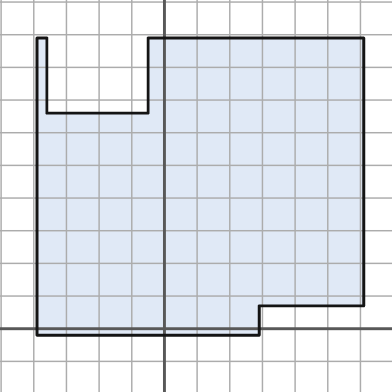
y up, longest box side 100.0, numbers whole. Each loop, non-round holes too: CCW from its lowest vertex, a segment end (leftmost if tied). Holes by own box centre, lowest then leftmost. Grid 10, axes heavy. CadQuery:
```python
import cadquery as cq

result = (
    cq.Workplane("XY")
    .moveTo(-39.0, -2.0)
    .lineTo(29.0, -2.0)
    .lineTo(29.0, 7.0)
    .lineTo(61.0, 7.0)
    .lineTo(61.0, 89.0)
    .lineTo(-5.0, 89.0)
    .lineTo(-5.0, 66.0)
    .lineTo(-36.0, 66.0)
    .lineTo(-36.0, 89.0)
    .lineTo(-39.0, 89.0)
    .close()
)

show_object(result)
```